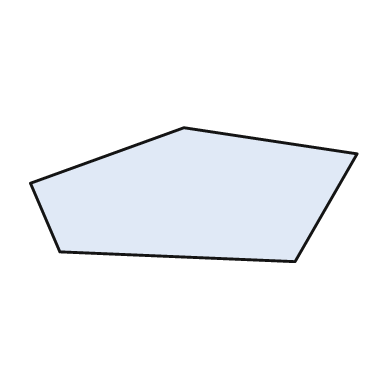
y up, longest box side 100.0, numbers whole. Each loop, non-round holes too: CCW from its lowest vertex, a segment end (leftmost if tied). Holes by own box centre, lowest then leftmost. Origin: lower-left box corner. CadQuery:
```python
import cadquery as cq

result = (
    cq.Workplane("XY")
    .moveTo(81.0, 0.0)
    .lineTo(100.0, 33.0)
    .lineTo(47.0, 41.0)
    .lineTo(0.0, 24.0)
    .lineTo(9.0, 3.0)
    .close()
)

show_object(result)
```